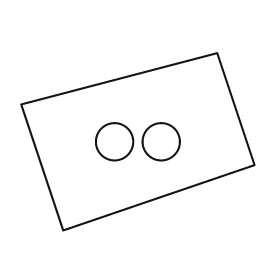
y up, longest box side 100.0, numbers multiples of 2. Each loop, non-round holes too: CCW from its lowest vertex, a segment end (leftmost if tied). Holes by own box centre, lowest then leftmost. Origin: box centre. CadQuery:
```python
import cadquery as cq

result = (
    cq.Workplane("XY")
    .moveTo(-32.0, -38.0)
    .lineTo(50.0, -10.0)
    .lineTo(34.0, 38.0)
    .lineTo(-50.0, 16.0)
    .close()
    .moveTo(-10.0, 0.0)
    .circle(8.0)
    .moveTo(10.0, 0.0)
    .circle(8.0)
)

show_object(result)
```